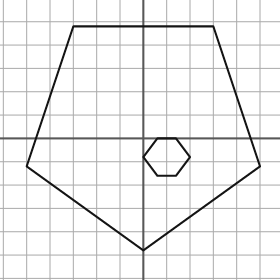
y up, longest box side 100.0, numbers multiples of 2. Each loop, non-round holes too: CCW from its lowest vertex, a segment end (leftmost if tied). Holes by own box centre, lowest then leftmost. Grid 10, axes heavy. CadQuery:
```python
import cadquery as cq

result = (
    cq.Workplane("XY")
    .moveTo(0.0, -48.0)
    .lineTo(50.0, -12.0)
    .lineTo(30.0, 48.0)
    .lineTo(-30.0, 48.0)
    .lineTo(-50.0, -12.0)
    .close()
    .moveTo(6.0, -16.0)
    .lineTo(14.0, -16.0)
    .lineTo(20.0, -8.0)
    .lineTo(14.0, 0.0)
    .lineTo(6.0, 0.0)
    .lineTo(0.0, -8.0)
    .close()
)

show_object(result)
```